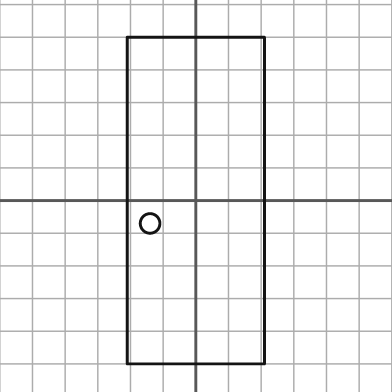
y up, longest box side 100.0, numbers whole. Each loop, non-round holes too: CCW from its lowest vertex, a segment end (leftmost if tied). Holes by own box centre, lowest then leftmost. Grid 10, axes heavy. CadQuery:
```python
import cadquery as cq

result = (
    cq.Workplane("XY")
    .moveTo(-21.0, -50.0)
    .lineTo(21.0, -50.0)
    .lineTo(21.0, 50.0)
    .lineTo(-21.0, 50.0)
    .close()
    .moveTo(-14.0, -7.0)
    .circle(3.0)
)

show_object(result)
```